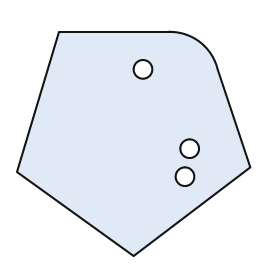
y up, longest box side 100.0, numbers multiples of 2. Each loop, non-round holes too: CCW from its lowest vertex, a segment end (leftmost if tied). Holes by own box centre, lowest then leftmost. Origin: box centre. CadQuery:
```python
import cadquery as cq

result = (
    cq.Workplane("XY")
    .moveTo(0.0, -48.0)
    .lineTo(50.0, -10.0)
    .lineTo(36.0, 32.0)
    .threePointArc((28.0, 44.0), (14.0, 48.0))
    .lineTo(-32.0, 48.0)
    .lineTo(-50.0, -12.0)
    .close()
    .moveTo(22.0, -14.0)
    .circle(4.0)
    .moveTo(24.0, -2.0)
    .circle(4.0)
    .moveTo(4.0, 32.0)
    .circle(4.0)
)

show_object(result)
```